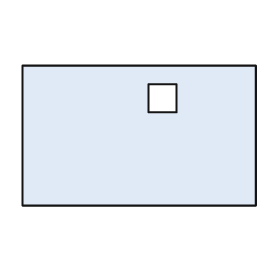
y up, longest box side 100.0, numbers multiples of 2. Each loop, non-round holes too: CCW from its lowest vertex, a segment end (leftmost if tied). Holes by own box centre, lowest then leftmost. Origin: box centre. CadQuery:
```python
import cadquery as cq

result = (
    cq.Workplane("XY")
    .moveTo(-50.0, -30.0)
    .lineTo(50.0, -30.0)
    .lineTo(50.0, 30.0)
    .lineTo(-50.0, 30.0)
    .close()
    .moveTo(4.0, 10.0)
    .lineTo(16.0, 10.0)
    .lineTo(16.0, 22.0)
    .lineTo(4.0, 22.0)
    .close()
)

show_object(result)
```